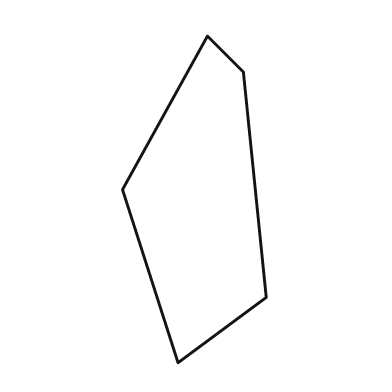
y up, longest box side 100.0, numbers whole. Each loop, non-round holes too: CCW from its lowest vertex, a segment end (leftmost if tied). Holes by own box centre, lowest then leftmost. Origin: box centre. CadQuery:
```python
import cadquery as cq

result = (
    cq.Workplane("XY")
    .moveTo(-5.0, -50.0)
    .lineTo(22.0, -30.0)
    .lineTo(15.0, 39.0)
    .lineTo(4.0, 50.0)
    .lineTo(-22.0, 3.0)
    .close()
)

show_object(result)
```